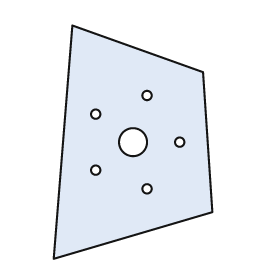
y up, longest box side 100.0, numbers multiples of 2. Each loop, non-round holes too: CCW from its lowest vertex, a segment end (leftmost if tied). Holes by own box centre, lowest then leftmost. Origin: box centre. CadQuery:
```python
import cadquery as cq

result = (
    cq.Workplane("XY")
    .moveTo(-34.0, -50.0)
    .lineTo(34.0, -30.0)
    .lineTo(30.0, 30.0)
    .lineTo(-26.0, 50.0)
    .close()
    .moveTo(6.0, -20.0)
    .circle(2.0)
    .moveTo(-16.0, -12.0)
    .circle(2.0)
    .moveTo(0.0, 0.0)
    .circle(6.0)
    .moveTo(20.0, 0.0)
    .circle(2.0)
    .moveTo(-16.0, 12.0)
    .circle(2.0)
    .moveTo(6.0, 20.0)
    .circle(2.0)
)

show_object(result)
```